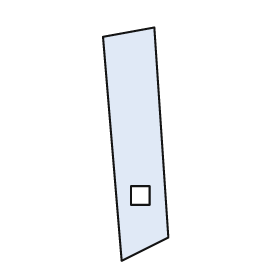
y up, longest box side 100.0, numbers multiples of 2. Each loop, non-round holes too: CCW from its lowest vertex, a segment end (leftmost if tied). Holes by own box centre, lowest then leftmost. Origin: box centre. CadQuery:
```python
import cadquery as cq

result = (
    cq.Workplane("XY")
    .moveTo(-6.0, -50.0)
    .lineTo(14.0, -40.0)
    .lineTo(8.0, 50.0)
    .lineTo(-14.0, 46.0)
    .close()
    .moveTo(-2.0, -26.0)
    .lineTo(6.0, -26.0)
    .lineTo(6.0, -18.0)
    .lineTo(-2.0, -18.0)
    .close()
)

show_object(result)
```